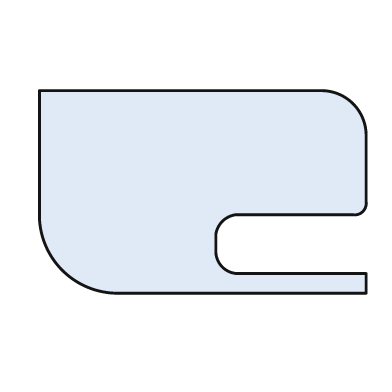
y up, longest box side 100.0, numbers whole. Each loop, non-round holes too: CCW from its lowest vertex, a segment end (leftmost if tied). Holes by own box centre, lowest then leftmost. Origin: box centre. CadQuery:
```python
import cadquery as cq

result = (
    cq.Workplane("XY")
    .moveTo(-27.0, -31.0)
    .lineTo(50.0, -31.0)
    .lineTo(50.0, -25.0)
    .lineTo(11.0, -25.0)
    .threePointArc((6.0, -23.0), (4.0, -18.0))
    .lineTo(4.0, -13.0)
    .threePointArc((6.0, -9.0), (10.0, -7.0))
    .lineTo(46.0, -7.0)
    .threePointArc((49.0, -6.0), (50.0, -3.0))
    .lineTo(50.0, 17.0)
    .threePointArc((46.0, 27.0), (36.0, 31.0))
    .lineTo(-50.0, 31.0)
    .lineTo(-50.0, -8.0)
    .threePointArc((-43.0, -24.0), (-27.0, -31.0))
    .close()
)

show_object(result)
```